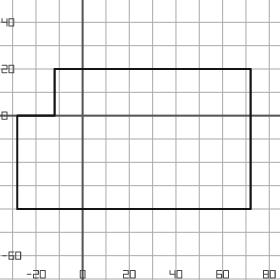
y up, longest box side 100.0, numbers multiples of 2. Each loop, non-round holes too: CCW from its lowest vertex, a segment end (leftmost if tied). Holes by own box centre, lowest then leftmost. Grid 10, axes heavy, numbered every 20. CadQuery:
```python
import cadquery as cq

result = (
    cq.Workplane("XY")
    .moveTo(-28.0, -40.0)
    .lineTo(72.0, -40.0)
    .lineTo(72.0, 20.0)
    .lineTo(-12.0, 20.0)
    .lineTo(-12.0, 0.0)
    .lineTo(-28.0, 0.0)
    .close()
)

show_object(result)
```